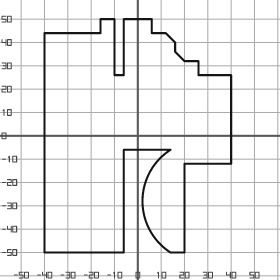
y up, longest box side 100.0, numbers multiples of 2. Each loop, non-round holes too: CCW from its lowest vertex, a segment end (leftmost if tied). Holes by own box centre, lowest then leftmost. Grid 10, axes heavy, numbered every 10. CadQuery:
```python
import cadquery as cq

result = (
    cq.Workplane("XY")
    .moveTo(-40.0, -50.0)
    .lineTo(-6.0, -50.0)
    .lineTo(-6.0, -6.0)
    .lineTo(14.0, -6.0)
    .threePointArc((2.0, -28.0), (14.0, -50.0))
    .lineTo(20.0, -50.0)
    .lineTo(20.0, -12.0)
    .lineTo(40.0, -12.0)
    .lineTo(40.0, 26.0)
    .lineTo(26.0, 26.0)
    .lineTo(26.0, 32.0)
    .lineTo(20.0, 32.0)
    .lineTo(16.0, 36.0)
    .lineTo(16.0, 40.0)
    .lineTo(12.0, 44.0)
    .lineTo(6.0, 44.0)
    .lineTo(6.0, 50.0)
    .lineTo(-6.0, 50.0)
    .lineTo(-6.0, 26.0)
    .lineTo(-10.0, 26.0)
    .lineTo(-10.0, 50.0)
    .lineTo(-16.0, 50.0)
    .lineTo(-16.0, 44.0)
    .lineTo(-40.0, 44.0)
    .close()
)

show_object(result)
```